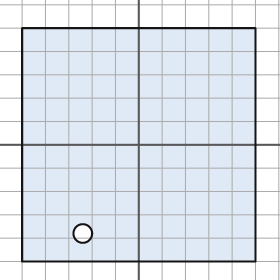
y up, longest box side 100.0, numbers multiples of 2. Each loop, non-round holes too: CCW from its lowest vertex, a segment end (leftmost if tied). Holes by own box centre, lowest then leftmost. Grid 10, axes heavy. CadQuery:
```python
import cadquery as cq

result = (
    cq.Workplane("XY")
    .moveTo(-50.0, -50.0)
    .lineTo(50.0, -50.0)
    .lineTo(50.0, 50.0)
    .lineTo(-50.0, 50.0)
    .close()
    .moveTo(-24.0, -38.0)
    .circle(4.0)
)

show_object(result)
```